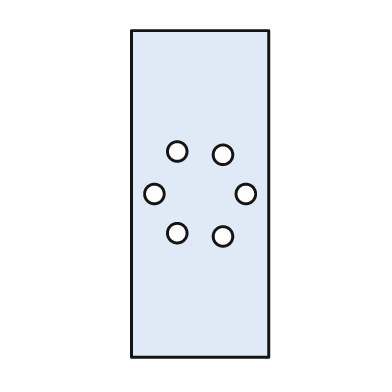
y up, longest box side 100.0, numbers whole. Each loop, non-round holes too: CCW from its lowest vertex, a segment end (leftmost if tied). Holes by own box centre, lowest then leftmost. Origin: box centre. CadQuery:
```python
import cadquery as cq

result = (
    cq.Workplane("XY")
    .moveTo(-21.0, -50.0)
    .lineTo(21.0, -50.0)
    .lineTo(21.0, 50.0)
    .lineTo(-21.0, 50.0)
    .close()
    .moveTo(7.0, -13.0)
    .circle(3.0)
    .moveTo(-7.0, -12.0)
    .circle(3.0)
    .moveTo(-14.0, 0.0)
    .circle(3.0)
    .moveTo(14.0, 0.0)
    .circle(3.0)
    .moveTo(7.0, 12.0)
    .circle(3.0)
    .moveTo(-7.0, 13.0)
    .circle(3.0)
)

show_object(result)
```